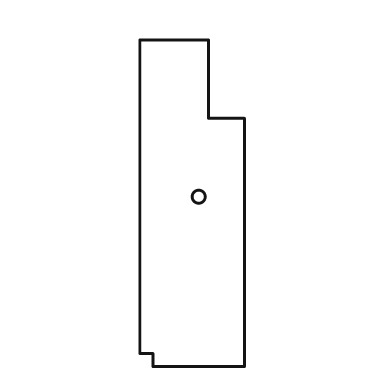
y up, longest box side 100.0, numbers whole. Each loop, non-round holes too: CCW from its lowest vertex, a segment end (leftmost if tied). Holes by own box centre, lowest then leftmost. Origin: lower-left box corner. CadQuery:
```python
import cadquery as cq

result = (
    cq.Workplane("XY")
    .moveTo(4.0, 0.0)
    .lineTo(32.0, 0.0)
    .lineTo(32.0, 76.0)
    .lineTo(21.0, 76.0)
    .lineTo(21.0, 100.0)
    .lineTo(0.0, 100.0)
    .lineTo(0.0, 4.0)
    .lineTo(4.0, 4.0)
    .close()
    .moveTo(18.0, 52.0)
    .circle(2.0)
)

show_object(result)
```